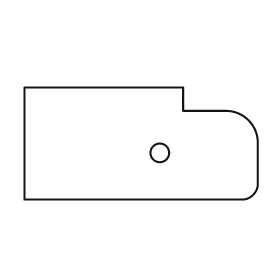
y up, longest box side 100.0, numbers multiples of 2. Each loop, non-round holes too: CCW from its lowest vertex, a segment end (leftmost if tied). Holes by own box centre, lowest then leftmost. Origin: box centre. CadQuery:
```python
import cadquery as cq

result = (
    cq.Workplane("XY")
    .moveTo(-50.0, -24.0)
    .lineTo(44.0, -24.0)
    .threePointArc((48.0, -22.0), (50.0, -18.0))
    .lineTo(50.0, 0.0)
    .threePointArc((46.0, 10.0), (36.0, 14.0))
    .lineTo(18.0, 14.0)
    .lineTo(18.0, 24.0)
    .lineTo(-50.0, 24.0)
    .close()
    .moveTo(8.0, -4.0)
    .circle(4.0)
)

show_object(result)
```